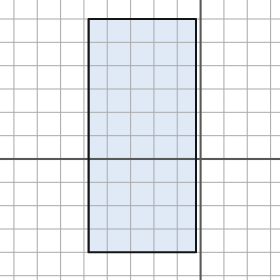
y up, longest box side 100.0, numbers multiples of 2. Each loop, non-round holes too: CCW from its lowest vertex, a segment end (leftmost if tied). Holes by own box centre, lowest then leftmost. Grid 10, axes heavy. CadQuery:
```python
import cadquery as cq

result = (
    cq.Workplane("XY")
    .moveTo(-48.0, -40.0)
    .lineTo(-2.0, -40.0)
    .lineTo(-2.0, 60.0)
    .lineTo(-48.0, 60.0)
    .close()
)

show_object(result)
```